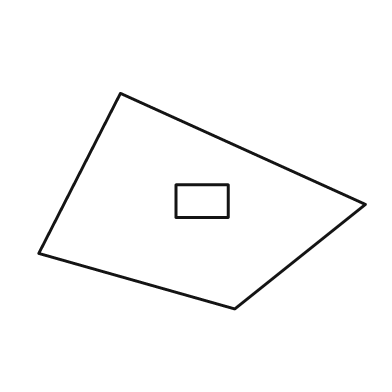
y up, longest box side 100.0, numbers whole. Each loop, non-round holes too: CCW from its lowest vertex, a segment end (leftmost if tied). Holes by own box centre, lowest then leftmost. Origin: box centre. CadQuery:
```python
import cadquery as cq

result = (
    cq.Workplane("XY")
    .moveTo(10.0, -33.0)
    .lineTo(50.0, -1.0)
    .lineTo(-25.0, 33.0)
    .lineTo(-50.0, -16.0)
    .close()
    .moveTo(-8.0, -5.0)
    .lineTo(8.0, -5.0)
    .lineTo(8.0, 5.0)
    .lineTo(-8.0, 5.0)
    .close()
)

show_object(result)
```